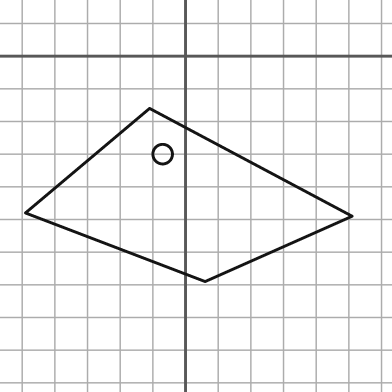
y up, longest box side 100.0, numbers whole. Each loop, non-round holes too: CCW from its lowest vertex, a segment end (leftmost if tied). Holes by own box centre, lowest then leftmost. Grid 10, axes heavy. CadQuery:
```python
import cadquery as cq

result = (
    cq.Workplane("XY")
    .moveTo(6.0, -69.0)
    .lineTo(51.0, -49.0)
    .lineTo(-11.0, -16.0)
    .lineTo(-49.0, -48.0)
    .close()
    .moveTo(-7.0, -30.0)
    .circle(3.0)
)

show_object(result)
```